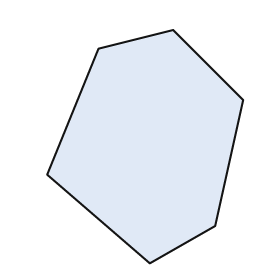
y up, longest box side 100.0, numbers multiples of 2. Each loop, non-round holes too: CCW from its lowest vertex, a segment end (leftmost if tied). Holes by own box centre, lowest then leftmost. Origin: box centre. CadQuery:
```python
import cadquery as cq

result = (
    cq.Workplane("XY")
    .moveTo(2.0, -50.0)
    .lineTo(30.0, -34.0)
    .lineTo(42.0, 20.0)
    .lineTo(12.0, 50.0)
    .lineTo(-20.0, 42.0)
    .lineTo(-42.0, -12.0)
    .close()
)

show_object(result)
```